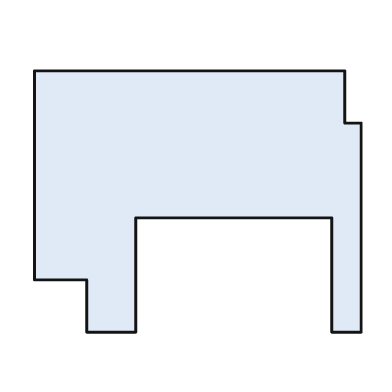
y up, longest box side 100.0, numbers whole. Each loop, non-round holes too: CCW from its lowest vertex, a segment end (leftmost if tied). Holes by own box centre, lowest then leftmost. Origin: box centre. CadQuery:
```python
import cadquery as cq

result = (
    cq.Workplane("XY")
    .moveTo(-34.0, -40.0)
    .lineTo(-19.0, -40.0)
    .lineTo(-19.0, -5.0)
    .lineTo(41.0, -5.0)
    .lineTo(41.0, -40.0)
    .lineTo(50.0, -40.0)
    .lineTo(50.0, 24.0)
    .lineTo(45.0, 24.0)
    .lineTo(45.0, 40.0)
    .lineTo(-50.0, 40.0)
    .lineTo(-50.0, -24.0)
    .lineTo(-34.0, -24.0)
    .close()
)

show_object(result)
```